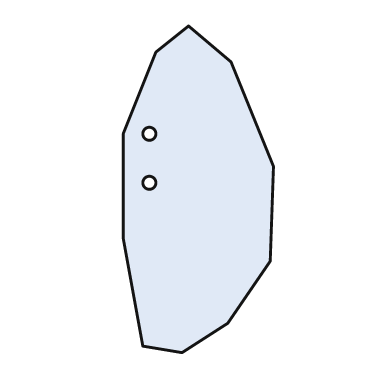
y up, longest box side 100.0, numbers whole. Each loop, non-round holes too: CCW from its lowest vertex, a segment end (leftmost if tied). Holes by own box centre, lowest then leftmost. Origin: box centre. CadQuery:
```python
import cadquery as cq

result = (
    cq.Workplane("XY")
    .moveTo(-5.0, -50.0)
    .lineTo(9.0, -41.0)
    .lineTo(22.0, -22.0)
    .lineTo(23.0, 7.0)
    .lineTo(10.0, 39.0)
    .lineTo(-3.0, 50.0)
    .lineTo(-13.0, 42.0)
    .lineTo(-23.0, 17.0)
    .lineTo(-23.0, -15.0)
    .lineTo(-17.0, -48.0)
    .close()
    .moveTo(-15.0, 2.0)
    .circle(2.0)
    .moveTo(-15.0, 17.0)
    .circle(2.0)
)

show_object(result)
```